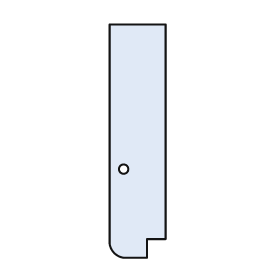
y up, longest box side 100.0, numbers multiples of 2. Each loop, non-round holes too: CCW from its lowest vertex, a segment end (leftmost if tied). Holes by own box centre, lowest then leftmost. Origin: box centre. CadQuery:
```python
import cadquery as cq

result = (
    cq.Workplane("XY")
    .moveTo(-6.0, -50.0)
    .lineTo(4.0, -50.0)
    .lineTo(4.0, -42.0)
    .lineTo(12.0, -42.0)
    .lineTo(12.0, 50.0)
    .lineTo(-12.0, 50.0)
    .lineTo(-12.0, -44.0)
    .threePointArc((-10.0, -48.0), (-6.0, -50.0))
    .close()
    .moveTo(-6.0, -12.0)
    .circle(2.0)
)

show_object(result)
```